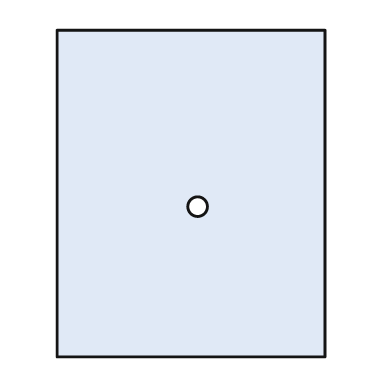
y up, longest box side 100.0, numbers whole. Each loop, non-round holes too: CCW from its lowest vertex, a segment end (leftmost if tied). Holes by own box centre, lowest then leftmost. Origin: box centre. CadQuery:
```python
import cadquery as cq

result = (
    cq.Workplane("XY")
    .moveTo(-41.0, -50.0)
    .lineTo(41.0, -50.0)
    .lineTo(41.0, 50.0)
    .lineTo(-41.0, 50.0)
    .close()
    .moveTo(2.0, -4.0)
    .circle(3.0)
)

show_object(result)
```